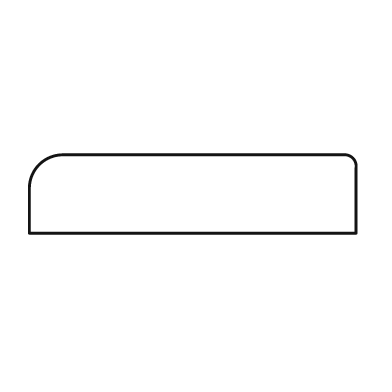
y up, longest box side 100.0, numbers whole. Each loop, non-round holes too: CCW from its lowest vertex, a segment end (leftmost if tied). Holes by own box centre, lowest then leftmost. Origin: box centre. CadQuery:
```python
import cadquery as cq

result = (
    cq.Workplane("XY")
    .moveTo(-50.0, -12.0)
    .lineTo(50.0, -12.0)
    .lineTo(50.0, 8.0)
    .threePointArc((49.0, 11.0), (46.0, 12.0))
    .lineTo(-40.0, 12.0)
    .threePointArc((-47.0, 9.0), (-50.0, 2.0))
    .close()
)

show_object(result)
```